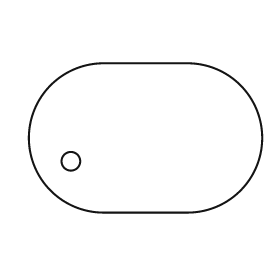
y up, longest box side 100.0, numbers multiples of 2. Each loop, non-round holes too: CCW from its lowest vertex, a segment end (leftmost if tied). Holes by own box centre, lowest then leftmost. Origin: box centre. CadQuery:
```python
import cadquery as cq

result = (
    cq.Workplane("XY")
    .moveTo(-18.0, -32.0)
    .lineTo(18.0, -32.0)
    .threePointArc((50.0, 0.0), (18.0, 32.0))
    .lineTo(-18.0, 32.0)
    .threePointArc((-50.0, 0.0), (-18.0, -32.0))
    .close()
    .moveTo(-32.0, -10.0)
    .circle(4.0)
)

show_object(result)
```